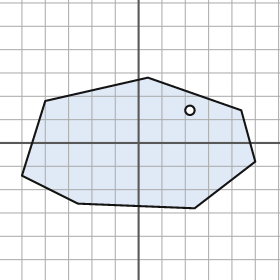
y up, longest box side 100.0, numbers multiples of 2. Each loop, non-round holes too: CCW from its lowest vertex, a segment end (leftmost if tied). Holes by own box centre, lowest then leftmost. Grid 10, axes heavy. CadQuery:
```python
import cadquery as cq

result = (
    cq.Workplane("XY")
    .moveTo(24.0, -28.0)
    .lineTo(50.0, -8.0)
    .lineTo(44.0, 14.0)
    .lineTo(4.0, 28.0)
    .lineTo(-40.0, 18.0)
    .lineTo(-50.0, -14.0)
    .lineTo(-26.0, -26.0)
    .close()
    .moveTo(22.0, 14.0)
    .circle(2.0)
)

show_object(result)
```